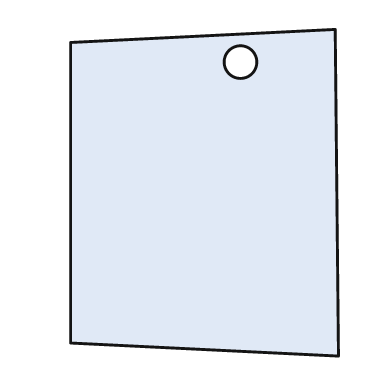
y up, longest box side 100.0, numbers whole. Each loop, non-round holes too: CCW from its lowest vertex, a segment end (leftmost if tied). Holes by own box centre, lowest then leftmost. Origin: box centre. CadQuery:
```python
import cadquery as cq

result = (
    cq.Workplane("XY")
    .moveTo(41.0, -50.0)
    .lineTo(40.0, 50.0)
    .lineTo(-41.0, 46.0)
    .lineTo(-41.0, -46.0)
    .close()
    .moveTo(11.0, 40.0)
    .circle(5.0)
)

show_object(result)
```